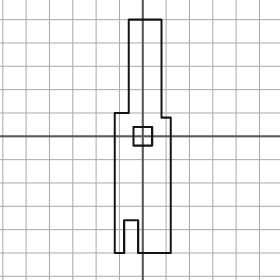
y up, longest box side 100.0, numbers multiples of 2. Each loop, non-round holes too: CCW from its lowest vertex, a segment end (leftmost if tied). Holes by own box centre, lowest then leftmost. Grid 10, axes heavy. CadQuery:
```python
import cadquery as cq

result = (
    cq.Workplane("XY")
    .moveTo(-12.0, -50.0)
    .lineTo(-8.0, -50.0)
    .lineTo(-8.0, -36.0)
    .lineTo(-2.0, -36.0)
    .lineTo(-2.0, -50.0)
    .lineTo(12.0, -50.0)
    .lineTo(12.0, 8.0)
    .lineTo(8.0, 8.0)
    .lineTo(8.0, 50.0)
    .lineTo(-6.0, 50.0)
    .lineTo(-6.0, 10.0)
    .lineTo(-12.0, 10.0)
    .close()
    .moveTo(-4.0, -4.0)
    .lineTo(4.0, -4.0)
    .lineTo(4.0, 4.0)
    .lineTo(-4.0, 4.0)
    .close()
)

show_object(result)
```